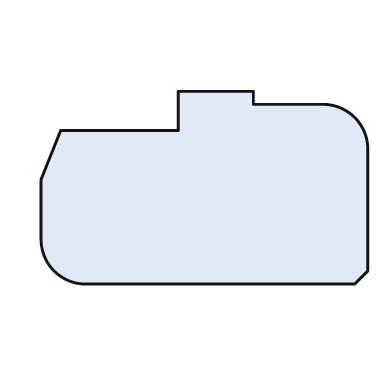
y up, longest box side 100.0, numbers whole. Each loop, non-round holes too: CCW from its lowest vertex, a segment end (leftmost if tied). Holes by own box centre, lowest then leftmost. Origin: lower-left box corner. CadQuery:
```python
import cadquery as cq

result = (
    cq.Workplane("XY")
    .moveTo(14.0, 0.0)
    .lineTo(96.0, 0.0)
    .lineTo(100.0, 4.0)
    .lineTo(100.0, 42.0)
    .threePointArc((96.0, 51.0), (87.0, 55.0))
    .lineTo(65.0, 55.0)
    .lineTo(65.0, 59.0)
    .lineTo(42.0, 59.0)
    .lineTo(42.0, 47.0)
    .lineTo(6.0, 47.0)
    .lineTo(0.0, 32.0)
    .lineTo(0.0, 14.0)
    .threePointArc((4.0, 4.0), (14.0, 0.0))
    .close()
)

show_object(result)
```